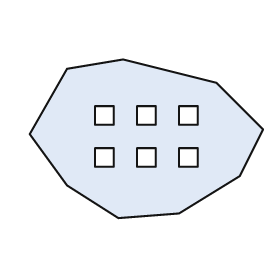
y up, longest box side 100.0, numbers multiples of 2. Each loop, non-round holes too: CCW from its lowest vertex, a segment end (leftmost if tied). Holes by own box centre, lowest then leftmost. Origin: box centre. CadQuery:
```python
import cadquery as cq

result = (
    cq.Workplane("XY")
    .moveTo(-12.0, -34.0)
    .lineTo(14.0, -32.0)
    .lineTo(40.0, -16.0)
    .lineTo(50.0, 4.0)
    .lineTo(30.0, 24.0)
    .lineTo(-10.0, 34.0)
    .lineTo(-34.0, 30.0)
    .lineTo(-50.0, 2.0)
    .lineTo(-34.0, -20.0)
    .close()
    .moveTo(-22.0, -12.0)
    .lineTo(-14.0, -12.0)
    .lineTo(-14.0, -4.0)
    .lineTo(-22.0, -4.0)
    .close()
    .moveTo(-4.0, -12.0)
    .lineTo(4.0, -12.0)
    .lineTo(4.0, -4.0)
    .lineTo(-4.0, -4.0)
    .close()
    .moveTo(14.0, -12.0)
    .lineTo(22.0, -12.0)
    .lineTo(22.0, -4.0)
    .lineTo(14.0, -4.0)
    .close()
    .moveTo(-22.0, 6.0)
    .lineTo(-14.0, 6.0)
    .lineTo(-14.0, 14.0)
    .lineTo(-22.0, 14.0)
    .close()
    .moveTo(-4.0, 6.0)
    .lineTo(4.0, 6.0)
    .lineTo(4.0, 14.0)
    .lineTo(-4.0, 14.0)
    .close()
    .moveTo(14.0, 6.0)
    .lineTo(22.0, 6.0)
    .lineTo(22.0, 14.0)
    .lineTo(14.0, 14.0)
    .close()
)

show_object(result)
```